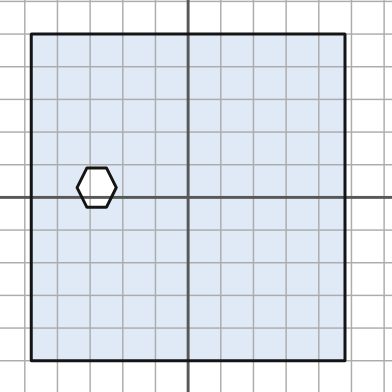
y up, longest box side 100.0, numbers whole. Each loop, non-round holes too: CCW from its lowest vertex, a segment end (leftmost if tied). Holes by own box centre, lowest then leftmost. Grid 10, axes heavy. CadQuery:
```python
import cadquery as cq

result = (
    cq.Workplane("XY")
    .moveTo(-48.0, -50.0)
    .lineTo(48.0, -50.0)
    .lineTo(48.0, 50.0)
    .lineTo(-48.0, 50.0)
    .close()
    .moveTo(-31.0, -3.0)
    .lineTo(-25.0, -3.0)
    .lineTo(-22.0, 3.0)
    .lineTo(-25.0, 9.0)
    .lineTo(-31.0, 9.0)
    .lineTo(-34.0, 3.0)
    .close()
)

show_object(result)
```